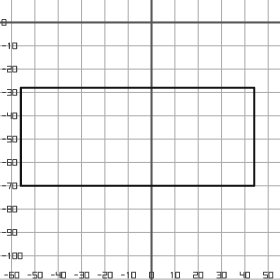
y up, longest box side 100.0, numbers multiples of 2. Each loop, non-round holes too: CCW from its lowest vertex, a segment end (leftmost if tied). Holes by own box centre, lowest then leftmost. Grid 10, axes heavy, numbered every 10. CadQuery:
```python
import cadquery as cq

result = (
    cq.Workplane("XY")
    .moveTo(-56.0, -70.0)
    .lineTo(44.0, -70.0)
    .lineTo(44.0, -28.0)
    .lineTo(-56.0, -28.0)
    .close()
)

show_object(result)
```